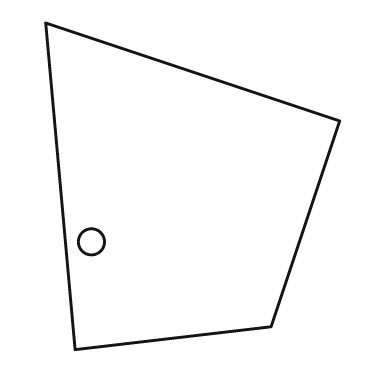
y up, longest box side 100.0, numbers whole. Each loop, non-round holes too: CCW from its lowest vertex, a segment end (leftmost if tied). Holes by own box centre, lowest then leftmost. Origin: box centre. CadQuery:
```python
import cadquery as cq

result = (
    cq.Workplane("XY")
    .moveTo(-36.0, -50.0)
    .lineTo(24.0, -43.0)
    .lineTo(45.0, 20.0)
    .lineTo(-45.0, 50.0)
    .close()
    .moveTo(-31.0, -17.0)
    .circle(4.0)
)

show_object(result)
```